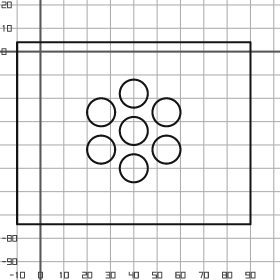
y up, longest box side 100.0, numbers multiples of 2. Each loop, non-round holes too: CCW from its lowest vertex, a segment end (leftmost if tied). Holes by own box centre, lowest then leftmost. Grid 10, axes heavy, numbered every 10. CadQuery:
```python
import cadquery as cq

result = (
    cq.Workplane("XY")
    .moveTo(-10.0, -74.0)
    .lineTo(90.0, -74.0)
    .lineTo(90.0, 4.0)
    .lineTo(-10.0, 4.0)
    .close()
    .moveTo(40.0, -50.0)
    .circle(6.0)
    .moveTo(26.0, -42.0)
    .circle(6.0)
    .moveTo(54.0, -42.0)
    .circle(6.0)
    .moveTo(40.0, -34.0)
    .circle(6.0)
    .moveTo(26.0, -26.0)
    .circle(6.0)
    .moveTo(54.0, -26.0)
    .circle(6.0)
    .moveTo(40.0, -18.0)
    .circle(6.0)
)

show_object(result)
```